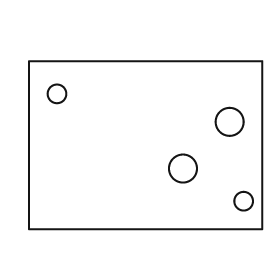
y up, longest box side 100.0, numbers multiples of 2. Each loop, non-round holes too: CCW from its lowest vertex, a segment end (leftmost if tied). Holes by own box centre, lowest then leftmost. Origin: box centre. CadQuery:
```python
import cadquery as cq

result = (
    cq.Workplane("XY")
    .moveTo(-50.0, -36.0)
    .lineTo(50.0, -36.0)
    .lineTo(50.0, 36.0)
    .lineTo(-50.0, 36.0)
    .close()
    .moveTo(42.0, -24.0)
    .circle(4.0)
    .moveTo(16.0, -10.0)
    .circle(6.0)
    .moveTo(36.0, 10.0)
    .circle(6.0)
    .moveTo(-38.0, 22.0)
    .circle(4.0)
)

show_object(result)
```